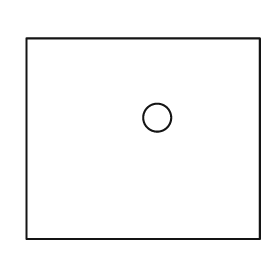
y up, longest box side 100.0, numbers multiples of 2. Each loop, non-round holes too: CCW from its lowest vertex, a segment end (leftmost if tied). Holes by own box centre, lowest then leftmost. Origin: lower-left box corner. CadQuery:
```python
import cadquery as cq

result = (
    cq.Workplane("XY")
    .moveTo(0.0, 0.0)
    .lineTo(100.0, 0.0)
    .lineTo(100.0, 86.0)
    .lineTo(0.0, 86.0)
    .close()
    .moveTo(56.0, 52.0)
    .circle(6.0)
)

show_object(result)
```